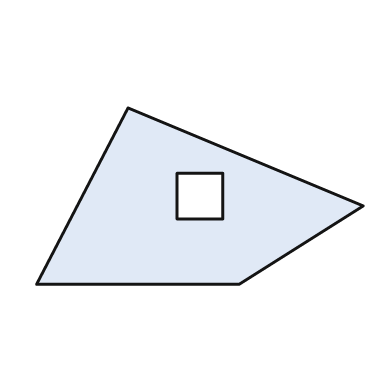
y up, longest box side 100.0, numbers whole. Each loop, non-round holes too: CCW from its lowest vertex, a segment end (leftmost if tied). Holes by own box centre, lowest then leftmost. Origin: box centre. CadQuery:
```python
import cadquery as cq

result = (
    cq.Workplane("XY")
    .moveTo(-50.0, -27.0)
    .lineTo(12.0, -27.0)
    .lineTo(50.0, -3.0)
    .lineTo(-22.0, 27.0)
    .close()
    .moveTo(-7.0, -7.0)
    .lineTo(7.0, -7.0)
    .lineTo(7.0, 7.0)
    .lineTo(-7.0, 7.0)
    .close()
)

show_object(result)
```